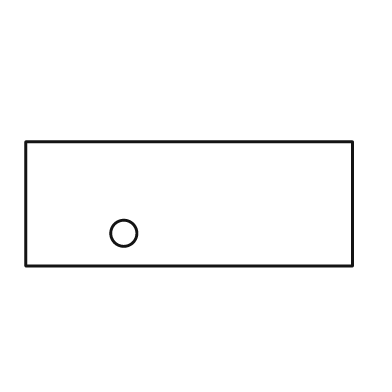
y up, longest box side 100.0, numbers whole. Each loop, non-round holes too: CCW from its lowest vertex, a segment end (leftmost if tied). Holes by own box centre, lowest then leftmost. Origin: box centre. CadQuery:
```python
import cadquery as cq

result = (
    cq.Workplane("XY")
    .moveTo(-50.0, -19.0)
    .lineTo(50.0, -19.0)
    .lineTo(50.0, 19.0)
    .lineTo(-50.0, 19.0)
    .close()
    .moveTo(-20.0, -9.0)
    .circle(4.0)
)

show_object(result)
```